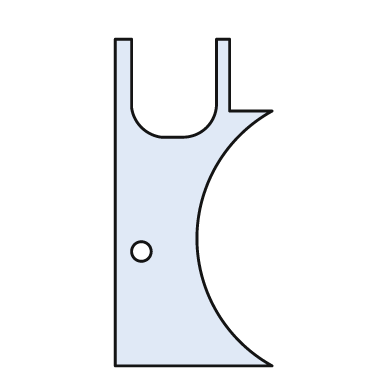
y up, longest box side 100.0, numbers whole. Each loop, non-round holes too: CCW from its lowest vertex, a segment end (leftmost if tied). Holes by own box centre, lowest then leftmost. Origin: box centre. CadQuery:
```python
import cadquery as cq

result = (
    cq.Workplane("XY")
    .moveTo(-24.0, -50.0)
    .lineTo(24.0, -50.0)
    .threePointArc((1.0, -11.0), (24.0, 28.0))
    .lineTo(11.0, 28.0)
    .lineTo(11.0, 50.0)
    .lineTo(7.0, 50.0)
    .lineTo(7.0, 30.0)
    .threePointArc((4.0, 23.0), (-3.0, 20.0))
    .lineTo(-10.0, 20.0)
    .threePointArc((-16.0, 23.0), (-19.0, 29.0))
    .lineTo(-19.0, 50.0)
    .lineTo(-24.0, 50.0)
    .close()
    .moveTo(-16.0, -15.0)
    .circle(3.0)
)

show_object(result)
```